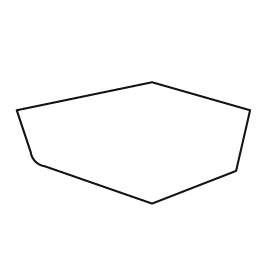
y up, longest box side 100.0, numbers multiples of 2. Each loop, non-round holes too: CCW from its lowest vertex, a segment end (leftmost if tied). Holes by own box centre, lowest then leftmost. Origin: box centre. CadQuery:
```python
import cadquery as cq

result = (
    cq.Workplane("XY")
    .moveTo(8.0, -26.0)
    .lineTo(44.0, -12.0)
    .lineTo(50.0, 14.0)
    .lineTo(8.0, 26.0)
    .lineTo(-50.0, 14.0)
    .lineTo(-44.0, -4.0)
    .threePointArc((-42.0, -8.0), (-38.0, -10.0))
    .close()
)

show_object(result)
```